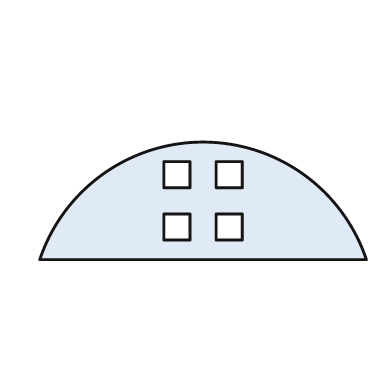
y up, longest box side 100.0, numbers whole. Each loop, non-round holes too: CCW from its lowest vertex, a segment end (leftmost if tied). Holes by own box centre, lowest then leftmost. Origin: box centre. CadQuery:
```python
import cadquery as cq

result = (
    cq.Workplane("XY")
    .moveTo(-50.0, -18.0)
    .lineTo(50.0, -18.0)
    .threePointArc((0.0, 18.0), (-50.0, -18.0))
    .close()
    .moveTo(-12.0, -12.0)
    .lineTo(-4.0, -12.0)
    .lineTo(-4.0, -4.0)
    .lineTo(-12.0, -4.0)
    .close()
    .moveTo(4.0, -12.0)
    .lineTo(12.0, -12.0)
    .lineTo(12.0, -4.0)
    .lineTo(4.0, -4.0)
    .close()
    .moveTo(-12.0, 4.0)
    .lineTo(-4.0, 4.0)
    .lineTo(-4.0, 12.0)
    .lineTo(-12.0, 12.0)
    .close()
    .moveTo(4.0, 4.0)
    .lineTo(12.0, 4.0)
    .lineTo(12.0, 12.0)
    .lineTo(4.0, 12.0)
    .close()
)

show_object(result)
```